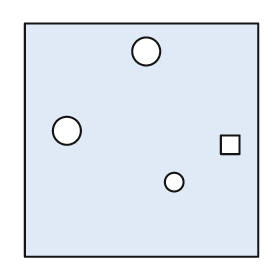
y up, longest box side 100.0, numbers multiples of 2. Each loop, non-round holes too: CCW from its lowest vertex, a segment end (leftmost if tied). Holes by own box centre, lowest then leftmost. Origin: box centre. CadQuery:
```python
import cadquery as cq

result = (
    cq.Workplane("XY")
    .moveTo(-50.0, -50.0)
    .lineTo(50.0, -50.0)
    .lineTo(50.0, 50.0)
    .lineTo(-50.0, 50.0)
    .close()
    .moveTo(14.0, -18.0)
    .circle(4.0)
    .moveTo(34.0, -6.0)
    .lineTo(42.0, -6.0)
    .lineTo(42.0, 2.0)
    .lineTo(34.0, 2.0)
    .close()
    .moveTo(-32.0, 4.0)
    .circle(6.0)
    .moveTo(2.0, 38.0)
    .circle(6.0)
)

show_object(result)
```